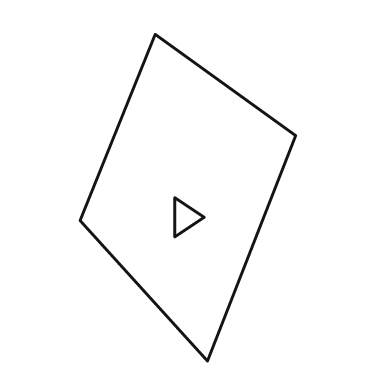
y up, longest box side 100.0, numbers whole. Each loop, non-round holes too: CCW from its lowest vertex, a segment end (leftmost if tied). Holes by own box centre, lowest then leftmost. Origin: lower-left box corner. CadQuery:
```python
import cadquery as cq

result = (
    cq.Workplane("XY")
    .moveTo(39.0, 0.0)
    .lineTo(66.0, 69.0)
    .lineTo(23.0, 100.0)
    .lineTo(0.0, 43.0)
    .close()
    .moveTo(29.0, 38.0)
    .lineTo(38.0, 44.0)
    .lineTo(29.0, 50.0)
    .close()
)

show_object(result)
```